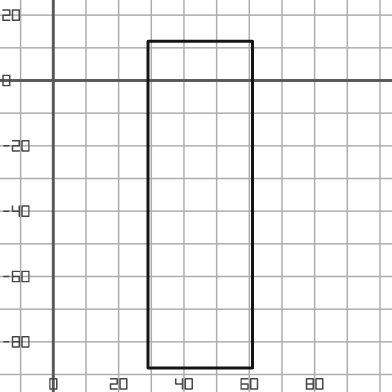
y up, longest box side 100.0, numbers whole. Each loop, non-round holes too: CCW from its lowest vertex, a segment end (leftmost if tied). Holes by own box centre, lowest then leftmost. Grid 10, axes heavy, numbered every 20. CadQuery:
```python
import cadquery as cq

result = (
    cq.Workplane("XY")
    .moveTo(29.0, -88.0)
    .lineTo(61.0, -88.0)
    .lineTo(61.0, 12.0)
    .lineTo(29.0, 12.0)
    .close()
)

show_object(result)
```